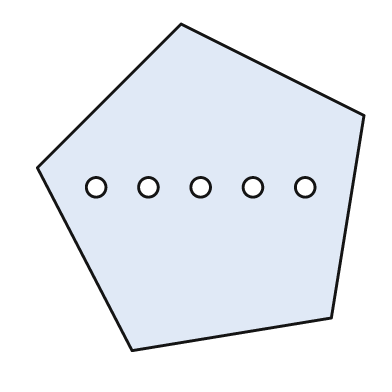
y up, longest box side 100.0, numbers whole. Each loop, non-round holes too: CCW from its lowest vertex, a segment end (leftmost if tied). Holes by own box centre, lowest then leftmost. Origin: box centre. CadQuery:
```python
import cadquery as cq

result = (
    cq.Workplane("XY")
    .moveTo(-21.0, -50.0)
    .lineTo(40.0, -40.0)
    .lineTo(50.0, 22.0)
    .lineTo(-6.0, 50.0)
    .lineTo(-50.0, 6.0)
    .close()
    .moveTo(-32.0, 0.0)
    .circle(3.0)
    .moveTo(-16.0, 0.0)
    .circle(3.0)
    .moveTo(0.0, 0.0)
    .circle(3.0)
    .moveTo(16.0, 0.0)
    .circle(3.0)
    .moveTo(32.0, 0.0)
    .circle(3.0)
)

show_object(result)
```